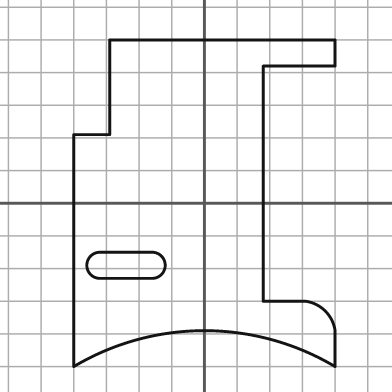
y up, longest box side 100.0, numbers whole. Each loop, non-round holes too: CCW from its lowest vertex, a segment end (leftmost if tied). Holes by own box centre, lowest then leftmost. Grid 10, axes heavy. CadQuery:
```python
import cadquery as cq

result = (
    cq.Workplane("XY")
    .moveTo(-40.0, -50.0)
    .threePointArc((0.0, -39.0), (40.0, -50.0))
    .lineTo(40.0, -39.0)
    .threePointArc((37.0, -33.0), (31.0, -30.0))
    .lineTo(18.0, -30.0)
    .lineTo(18.0, 42.0)
    .lineTo(40.0, 42.0)
    .lineTo(40.0, 50.0)
    .lineTo(-29.0, 50.0)
    .lineTo(-29.0, 21.0)
    .lineTo(-40.0, 21.0)
    .close()
    .moveTo(-32.0, -23.0)
    .lineTo(-16.0, -23.0)
    .threePointArc((-12.0, -19.0), (-16.0, -15.0))
    .lineTo(-32.0, -15.0)
    .threePointArc((-36.0, -19.0), (-32.0, -23.0))
    .close()
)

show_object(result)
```